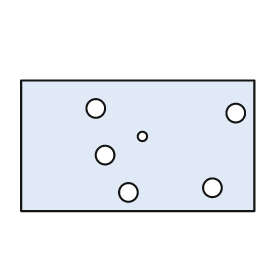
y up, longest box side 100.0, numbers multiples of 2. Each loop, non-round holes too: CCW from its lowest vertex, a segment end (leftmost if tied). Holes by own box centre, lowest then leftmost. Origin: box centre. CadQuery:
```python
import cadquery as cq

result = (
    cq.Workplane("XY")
    .moveTo(-50.0, -28.0)
    .lineTo(50.0, -28.0)
    .lineTo(50.0, 28.0)
    .lineTo(-50.0, 28.0)
    .close()
    .moveTo(-4.0, -20.0)
    .circle(4.0)
    .moveTo(32.0, -18.0)
    .circle(4.0)
    .moveTo(-14.0, -4.0)
    .circle(4.0)
    .moveTo(2.0, 4.0)
    .circle(2.0)
    .moveTo(42.0, 14.0)
    .circle(4.0)
    .moveTo(-18.0, 16.0)
    .circle(4.0)
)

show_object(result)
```